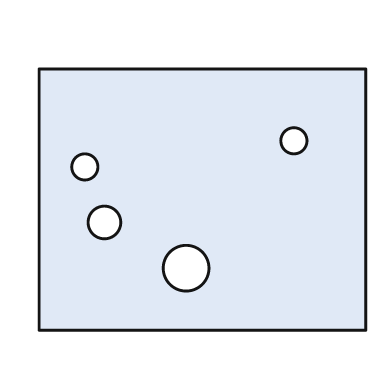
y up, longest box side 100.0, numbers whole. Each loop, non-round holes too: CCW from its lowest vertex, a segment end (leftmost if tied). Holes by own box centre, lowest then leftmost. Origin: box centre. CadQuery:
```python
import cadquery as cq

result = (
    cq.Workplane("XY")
    .moveTo(-50.0, -40.0)
    .lineTo(50.0, -40.0)
    .lineTo(50.0, 40.0)
    .lineTo(-50.0, 40.0)
    .close()
    .moveTo(-5.0, -21.0)
    .circle(7.0)
    .moveTo(-30.0, -7.0)
    .circle(5.0)
    .moveTo(-36.0, 10.0)
    .circle(4.0)
    .moveTo(28.0, 18.0)
    .circle(4.0)
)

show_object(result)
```